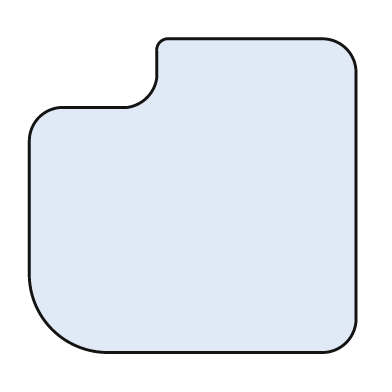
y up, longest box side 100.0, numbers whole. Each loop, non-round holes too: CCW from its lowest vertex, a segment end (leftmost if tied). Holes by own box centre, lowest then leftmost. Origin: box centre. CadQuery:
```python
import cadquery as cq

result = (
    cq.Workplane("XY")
    .moveTo(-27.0, -48.0)
    .lineTo(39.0, -48.0)
    .threePointArc((47.0, -45.0), (50.0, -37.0))
    .lineTo(50.0, 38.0)
    .threePointArc((47.0, 45.0), (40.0, 48.0))
    .lineTo(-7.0, 48.0)
    .threePointArc((-10.0, 47.0), (-11.0, 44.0))
    .lineTo(-11.0, 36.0)
    .threePointArc((-14.0, 30.0), (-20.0, 27.0))
    .lineTo(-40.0, 27.0)
    .threePointArc((-47.0, 24.0), (-50.0, 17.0))
    .lineTo(-50.0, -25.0)
    .threePointArc((-43.0, -41.0), (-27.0, -48.0))
    .close()
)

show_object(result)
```